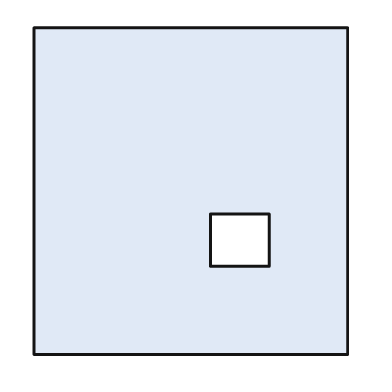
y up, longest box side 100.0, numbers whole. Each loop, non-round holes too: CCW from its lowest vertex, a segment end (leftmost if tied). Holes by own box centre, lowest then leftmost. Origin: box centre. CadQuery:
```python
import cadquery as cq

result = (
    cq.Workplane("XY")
    .moveTo(-48.0, -50.0)
    .lineTo(48.0, -50.0)
    .lineTo(48.0, 50.0)
    .lineTo(-48.0, 50.0)
    .close()
    .moveTo(6.0, -23.0)
    .lineTo(24.0, -23.0)
    .lineTo(24.0, -7.0)
    .lineTo(6.0, -7.0)
    .close()
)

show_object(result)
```